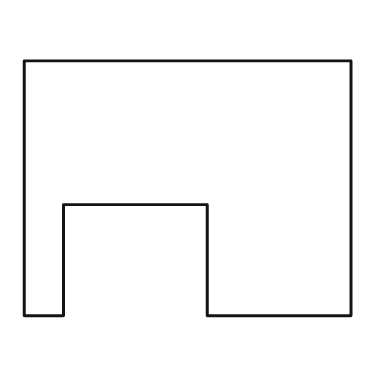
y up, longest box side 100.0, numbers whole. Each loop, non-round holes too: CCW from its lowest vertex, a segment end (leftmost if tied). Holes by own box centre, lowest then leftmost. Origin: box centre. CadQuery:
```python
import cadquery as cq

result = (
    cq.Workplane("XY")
    .moveTo(-50.0, -39.0)
    .lineTo(-38.0, -39.0)
    .lineTo(-38.0, -5.0)
    .lineTo(6.0, -5.0)
    .lineTo(6.0, -39.0)
    .lineTo(50.0, -39.0)
    .lineTo(50.0, 39.0)
    .lineTo(-50.0, 39.0)
    .close()
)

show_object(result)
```